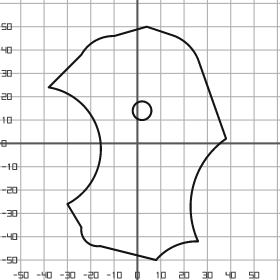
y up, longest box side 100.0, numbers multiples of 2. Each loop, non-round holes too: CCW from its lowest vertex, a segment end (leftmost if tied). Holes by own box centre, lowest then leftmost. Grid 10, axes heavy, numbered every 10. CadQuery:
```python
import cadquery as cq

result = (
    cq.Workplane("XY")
    .moveTo(8.0, -50.0)
    .threePointArc((16.0, -44.0), (26.0, -42.0))
    .threePointArc((24.0, -18.0), (38.0, 2.0))
    .lineTo(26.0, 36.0)
    .threePointArc((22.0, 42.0), (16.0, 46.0))
    .lineTo(4.0, 50.0)
    .lineTo(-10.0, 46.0)
    .threePointArc((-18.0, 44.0), (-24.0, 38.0))
    .lineTo(-38.0, 24.0)
    .threePointArc((-16.0, 2.0), (-30.0, -26.0))
    .lineTo(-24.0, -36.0)
    .threePointArc((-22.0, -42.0), (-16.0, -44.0))
    .close()
    .moveTo(2.0, 14.0)
    .circle(4.0)
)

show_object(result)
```